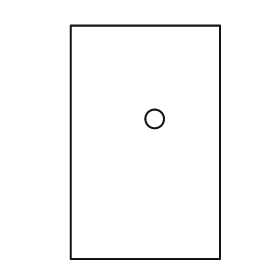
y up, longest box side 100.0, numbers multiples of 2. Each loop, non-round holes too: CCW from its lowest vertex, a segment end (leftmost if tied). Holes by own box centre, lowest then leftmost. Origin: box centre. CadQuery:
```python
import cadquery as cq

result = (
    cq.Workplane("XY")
    .moveTo(-32.0, -50.0)
    .lineTo(32.0, -50.0)
    .lineTo(32.0, 50.0)
    .lineTo(-32.0, 50.0)
    .close()
    .moveTo(4.0, 10.0)
    .circle(4.0)
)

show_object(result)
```